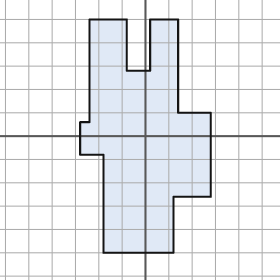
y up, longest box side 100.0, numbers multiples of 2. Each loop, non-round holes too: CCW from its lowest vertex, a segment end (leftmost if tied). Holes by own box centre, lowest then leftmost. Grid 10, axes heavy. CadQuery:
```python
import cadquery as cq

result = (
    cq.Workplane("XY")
    .moveTo(-18.0, -50.0)
    .lineTo(12.0, -50.0)
    .lineTo(12.0, -26.0)
    .lineTo(28.0, -26.0)
    .lineTo(28.0, 10.0)
    .lineTo(14.0, 10.0)
    .lineTo(14.0, 50.0)
    .lineTo(2.0, 50.0)
    .lineTo(2.0, 28.0)
    .lineTo(-8.0, 28.0)
    .lineTo(-8.0, 50.0)
    .lineTo(-24.0, 50.0)
    .lineTo(-24.0, 6.0)
    .lineTo(-28.0, 6.0)
    .lineTo(-28.0, -8.0)
    .lineTo(-18.0, -8.0)
    .close()
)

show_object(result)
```